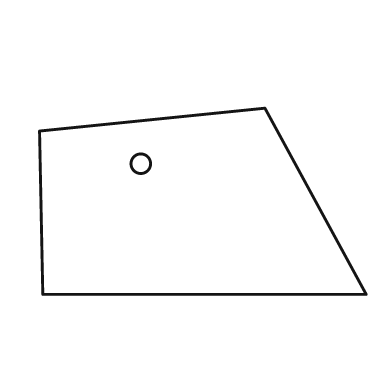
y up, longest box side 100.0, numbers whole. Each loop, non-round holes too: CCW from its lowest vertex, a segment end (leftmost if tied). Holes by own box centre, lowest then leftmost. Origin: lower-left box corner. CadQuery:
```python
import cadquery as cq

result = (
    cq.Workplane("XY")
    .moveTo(1.0, 0.0)
    .lineTo(100.0, 0.0)
    .lineTo(69.0, 57.0)
    .lineTo(0.0, 50.0)
    .close()
    .moveTo(31.0, 40.0)
    .circle(3.0)
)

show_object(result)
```